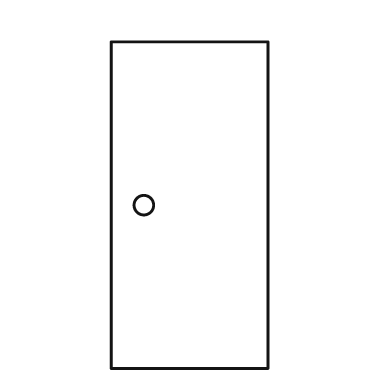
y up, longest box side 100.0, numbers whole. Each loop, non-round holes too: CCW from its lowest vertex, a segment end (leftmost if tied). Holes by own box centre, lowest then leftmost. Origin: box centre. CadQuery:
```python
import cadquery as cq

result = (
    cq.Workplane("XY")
    .moveTo(-24.0, -50.0)
    .lineTo(24.0, -50.0)
    .lineTo(24.0, 50.0)
    .lineTo(-24.0, 50.0)
    .close()
    .moveTo(-14.0, 0.0)
    .circle(3.0)
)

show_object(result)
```